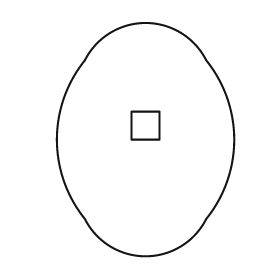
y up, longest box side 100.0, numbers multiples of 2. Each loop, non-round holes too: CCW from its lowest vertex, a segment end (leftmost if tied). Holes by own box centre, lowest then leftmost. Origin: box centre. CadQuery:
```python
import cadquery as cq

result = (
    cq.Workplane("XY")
    .moveTo(-26.0, -34.0)
    .threePointArc((0.0, -50.0), (26.0, -34.0))
    .threePointArc((38.0, 0.0), (26.0, 34.0))
    .threePointArc((0.0, 50.0), (-26.0, 34.0))
    .threePointArc((-38.0, 0.0), (-26.0, -34.0))
    .close()
    .moveTo(-6.0, 0.0)
    .lineTo(6.0, 0.0)
    .lineTo(6.0, 12.0)
    .lineTo(-6.0, 12.0)
    .close()
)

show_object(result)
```